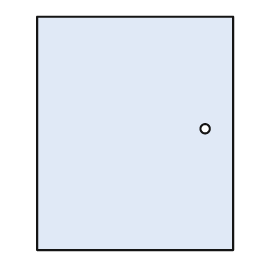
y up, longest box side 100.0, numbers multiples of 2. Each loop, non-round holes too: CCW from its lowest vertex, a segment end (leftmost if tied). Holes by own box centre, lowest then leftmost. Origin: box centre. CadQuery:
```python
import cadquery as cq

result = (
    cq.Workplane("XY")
    .moveTo(-42.0, -50.0)
    .lineTo(42.0, -50.0)
    .lineTo(42.0, 50.0)
    .lineTo(-42.0, 50.0)
    .close()
    .moveTo(30.0, 2.0)
    .circle(2.0)
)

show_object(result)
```